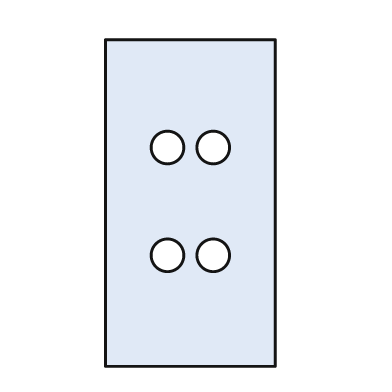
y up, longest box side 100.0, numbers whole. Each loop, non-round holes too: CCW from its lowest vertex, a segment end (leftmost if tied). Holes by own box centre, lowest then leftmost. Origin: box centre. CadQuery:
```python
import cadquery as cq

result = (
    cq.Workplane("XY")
    .moveTo(-26.0, -50.0)
    .lineTo(26.0, -50.0)
    .lineTo(26.0, 50.0)
    .lineTo(-26.0, 50.0)
    .close()
    .moveTo(-7.0, -16.0)
    .circle(5.0)
    .moveTo(7.0, -16.0)
    .circle(5.0)
    .moveTo(-7.0, 17.0)
    .circle(5.0)
    .moveTo(7.0, 17.0)
    .circle(5.0)
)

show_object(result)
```